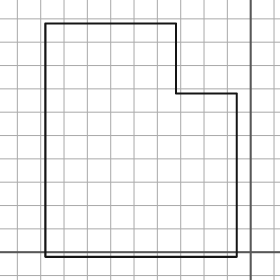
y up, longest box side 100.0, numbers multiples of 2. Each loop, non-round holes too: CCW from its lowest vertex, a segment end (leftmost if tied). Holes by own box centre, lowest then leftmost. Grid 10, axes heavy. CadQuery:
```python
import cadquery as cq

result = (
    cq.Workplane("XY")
    .moveTo(-88.0, -2.0)
    .lineTo(-6.0, -2.0)
    .lineTo(-6.0, 68.0)
    .lineTo(-32.0, 68.0)
    .lineTo(-32.0, 98.0)
    .lineTo(-88.0, 98.0)
    .close()
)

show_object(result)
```